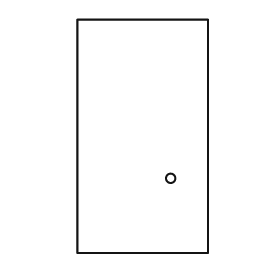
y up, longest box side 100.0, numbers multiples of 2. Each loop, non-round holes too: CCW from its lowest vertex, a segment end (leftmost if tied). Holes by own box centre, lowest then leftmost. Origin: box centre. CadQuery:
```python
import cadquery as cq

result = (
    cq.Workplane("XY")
    .moveTo(-28.0, -50.0)
    .lineTo(28.0, -50.0)
    .lineTo(28.0, 50.0)
    .lineTo(-28.0, 50.0)
    .close()
    .moveTo(12.0, -18.0)
    .circle(2.0)
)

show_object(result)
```